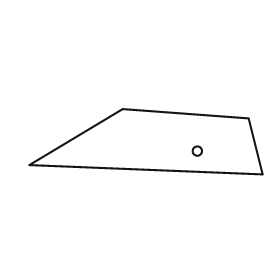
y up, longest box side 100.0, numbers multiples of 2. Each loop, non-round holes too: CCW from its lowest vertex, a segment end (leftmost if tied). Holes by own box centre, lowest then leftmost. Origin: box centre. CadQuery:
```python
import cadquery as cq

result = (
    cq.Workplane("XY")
    .moveTo(50.0, -14.0)
    .lineTo(44.0, 10.0)
    .lineTo(-10.0, 14.0)
    .lineTo(-50.0, -10.0)
    .close()
    .moveTo(22.0, -4.0)
    .circle(2.0)
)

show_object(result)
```